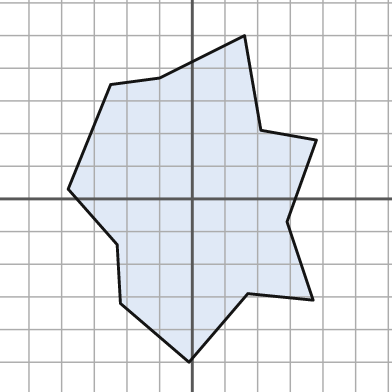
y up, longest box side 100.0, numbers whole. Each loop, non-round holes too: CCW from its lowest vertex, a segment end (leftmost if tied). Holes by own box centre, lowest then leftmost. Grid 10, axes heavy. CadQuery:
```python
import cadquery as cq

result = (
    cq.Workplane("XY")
    .moveTo(-1.0, -50.0)
    .lineTo(17.0, -29.0)
    .lineTo(37.0, -31.0)
    .lineTo(29.0, -7.0)
    .lineTo(38.0, 18.0)
    .lineTo(21.0, 21.0)
    .lineTo(16.0, 50.0)
    .lineTo(-10.0, 37.0)
    .lineTo(-25.0, 35.0)
    .lineTo(-38.0, 3.0)
    .lineTo(-23.0, -14.0)
    .lineTo(-22.0, -32.0)
    .close()
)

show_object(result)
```